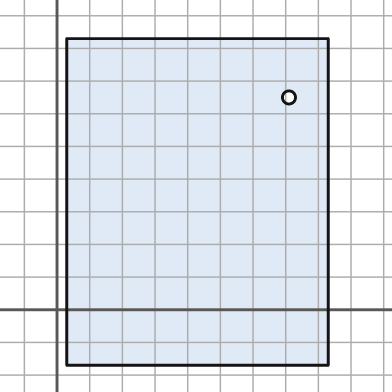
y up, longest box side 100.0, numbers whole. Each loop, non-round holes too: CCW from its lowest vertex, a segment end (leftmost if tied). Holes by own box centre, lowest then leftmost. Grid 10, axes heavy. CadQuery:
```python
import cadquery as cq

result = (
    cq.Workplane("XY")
    .moveTo(3.0, -17.0)
    .lineTo(83.0, -17.0)
    .lineTo(83.0, 83.0)
    .lineTo(3.0, 83.0)
    .close()
    .moveTo(71.0, 65.0)
    .circle(2.0)
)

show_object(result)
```